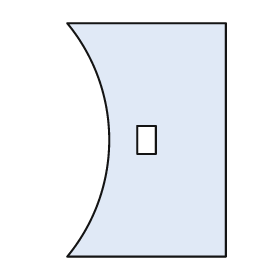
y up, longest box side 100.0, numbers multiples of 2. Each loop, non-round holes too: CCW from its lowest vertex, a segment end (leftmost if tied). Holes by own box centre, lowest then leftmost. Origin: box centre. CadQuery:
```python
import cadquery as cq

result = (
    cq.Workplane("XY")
    .moveTo(-34.0, -50.0)
    .lineTo(34.0, -50.0)
    .lineTo(34.0, 50.0)
    .lineTo(-34.0, 50.0)
    .threePointArc((-16.0, 0.0), (-34.0, -50.0))
    .close()
    .moveTo(-4.0, -6.0)
    .lineTo(4.0, -6.0)
    .lineTo(4.0, 6.0)
    .lineTo(-4.0, 6.0)
    .close()
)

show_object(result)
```